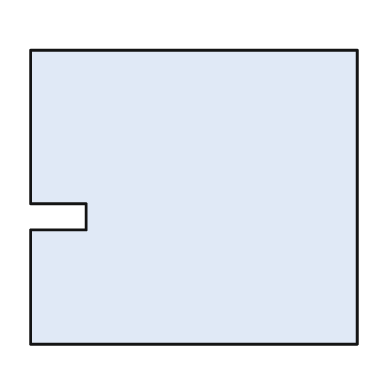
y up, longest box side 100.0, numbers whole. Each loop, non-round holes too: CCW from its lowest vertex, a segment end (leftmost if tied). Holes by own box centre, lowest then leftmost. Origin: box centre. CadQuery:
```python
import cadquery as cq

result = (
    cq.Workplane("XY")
    .moveTo(-50.0, -45.0)
    .lineTo(50.0, -45.0)
    .lineTo(50.0, 45.0)
    .lineTo(-50.0, 45.0)
    .lineTo(-50.0, -2.0)
    .lineTo(-33.0, -2.0)
    .lineTo(-33.0, -10.0)
    .lineTo(-50.0, -10.0)
    .close()
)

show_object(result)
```